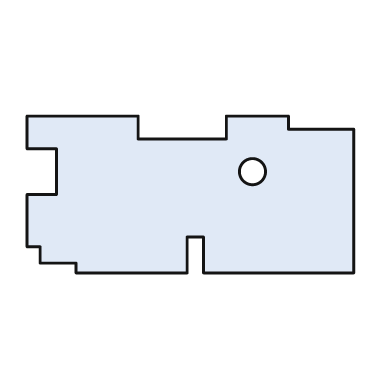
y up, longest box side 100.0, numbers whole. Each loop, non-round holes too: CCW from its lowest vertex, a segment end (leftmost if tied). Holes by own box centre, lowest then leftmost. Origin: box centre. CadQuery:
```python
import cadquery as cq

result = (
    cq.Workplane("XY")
    .moveTo(-35.0, -24.0)
    .lineTo(-1.0, -24.0)
    .lineTo(-1.0, -13.0)
    .lineTo(4.0, -13.0)
    .lineTo(4.0, -24.0)
    .lineTo(50.0, -24.0)
    .lineTo(50.0, 20.0)
    .lineTo(30.0, 20.0)
    .lineTo(30.0, 24.0)
    .lineTo(11.0, 24.0)
    .lineTo(11.0, 17.0)
    .lineTo(-16.0, 17.0)
    .lineTo(-16.0, 24.0)
    .lineTo(-50.0, 24.0)
    .lineTo(-50.0, 14.0)
    .lineTo(-41.0, 14.0)
    .lineTo(-41.0, 0.0)
    .lineTo(-50.0, 0.0)
    .lineTo(-50.0, -16.0)
    .lineTo(-46.0, -16.0)
    .lineTo(-46.0, -21.0)
    .lineTo(-35.0, -21.0)
    .close()
    .moveTo(19.0, 7.0)
    .circle(4.0)
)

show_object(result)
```